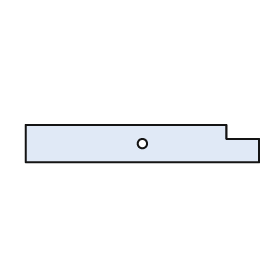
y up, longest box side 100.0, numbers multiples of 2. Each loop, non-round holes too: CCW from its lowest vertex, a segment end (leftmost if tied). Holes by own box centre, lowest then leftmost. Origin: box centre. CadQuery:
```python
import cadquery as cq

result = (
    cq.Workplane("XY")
    .moveTo(-50.0, -8.0)
    .lineTo(50.0, -8.0)
    .lineTo(50.0, 2.0)
    .lineTo(36.0, 2.0)
    .lineTo(36.0, 8.0)
    .lineTo(-50.0, 8.0)
    .close()
    .moveTo(0.0, 0.0)
    .circle(2.0)
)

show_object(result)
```